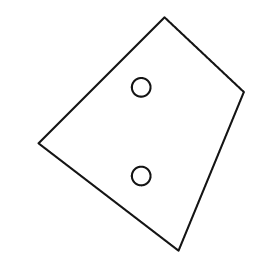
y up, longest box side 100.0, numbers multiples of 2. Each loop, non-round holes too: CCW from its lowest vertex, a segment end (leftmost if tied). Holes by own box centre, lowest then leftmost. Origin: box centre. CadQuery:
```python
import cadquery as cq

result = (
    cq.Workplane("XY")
    .moveTo(16.0, -50.0)
    .lineTo(44.0, 18.0)
    .lineTo(10.0, 50.0)
    .lineTo(-44.0, -4.0)
    .close()
    .moveTo(0.0, -18.0)
    .circle(4.0)
    .moveTo(0.0, 20.0)
    .circle(4.0)
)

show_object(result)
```